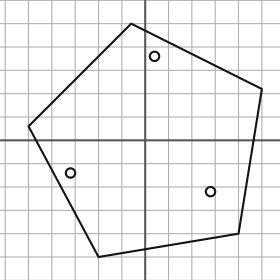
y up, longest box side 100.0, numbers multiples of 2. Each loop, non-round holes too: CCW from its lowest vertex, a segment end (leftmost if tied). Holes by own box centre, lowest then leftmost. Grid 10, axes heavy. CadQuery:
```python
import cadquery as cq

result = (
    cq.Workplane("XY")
    .moveTo(-20.0, -50.0)
    .lineTo(40.0, -40.0)
    .lineTo(50.0, 22.0)
    .lineTo(-6.0, 50.0)
    .lineTo(-50.0, 6.0)
    .close()
    .moveTo(28.0, -22.0)
    .circle(2.0)
    .moveTo(-32.0, -14.0)
    .circle(2.0)
    .moveTo(4.0, 36.0)
    .circle(2.0)
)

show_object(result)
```